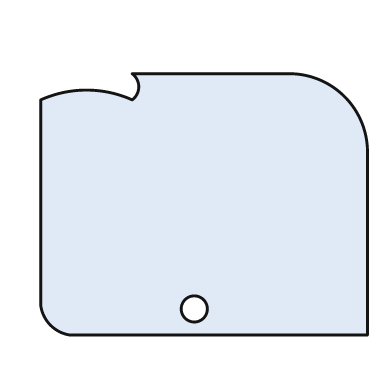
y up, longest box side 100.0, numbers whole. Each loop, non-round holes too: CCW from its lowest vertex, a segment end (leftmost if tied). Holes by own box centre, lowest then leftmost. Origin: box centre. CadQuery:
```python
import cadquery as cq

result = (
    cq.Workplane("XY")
    .moveTo(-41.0, -40.0)
    .lineTo(50.0, -40.0)
    .lineTo(50.0, 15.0)
    .threePointArc((43.0, 33.0), (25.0, 40.0))
    .lineTo(-22.0, 40.0)
    .threePointArc((-20.0, 36.0), (-22.0, 32.0))
    .threePointArc((-36.0, 35.0), (-50.0, 32.0))
    .lineTo(-50.0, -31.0)
    .threePointArc((-47.0, -37.0), (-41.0, -40.0))
    .close()
    .moveTo(-3.0, -32.0)
    .circle(4.0)
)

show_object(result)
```